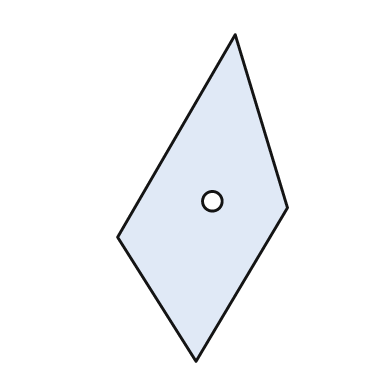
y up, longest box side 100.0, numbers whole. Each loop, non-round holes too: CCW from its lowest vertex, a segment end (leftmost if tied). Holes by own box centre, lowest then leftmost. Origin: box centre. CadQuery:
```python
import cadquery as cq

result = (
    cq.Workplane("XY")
    .moveTo(-2.0, -50.0)
    .lineTo(26.0, -3.0)
    .lineTo(10.0, 50.0)
    .lineTo(-26.0, -12.0)
    .close()
    .moveTo(3.0, -1.0)
    .circle(3.0)
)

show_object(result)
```